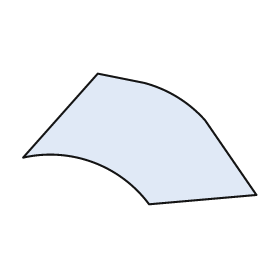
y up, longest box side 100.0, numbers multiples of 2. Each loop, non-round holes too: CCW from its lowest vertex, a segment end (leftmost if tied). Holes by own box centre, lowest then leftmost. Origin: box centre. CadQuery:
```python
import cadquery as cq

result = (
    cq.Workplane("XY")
    .moveTo(4.0, -28.0)
    .lineTo(50.0, -24.0)
    .lineTo(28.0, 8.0)
    .threePointArc((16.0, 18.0), (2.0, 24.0))
    .lineTo(-18.0, 28.0)
    .lineTo(-50.0, -8.0)
    .threePointArc((-20.0, -10.0), (4.0, -28.0))
    .close()
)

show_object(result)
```